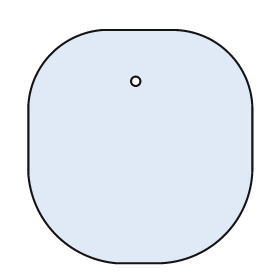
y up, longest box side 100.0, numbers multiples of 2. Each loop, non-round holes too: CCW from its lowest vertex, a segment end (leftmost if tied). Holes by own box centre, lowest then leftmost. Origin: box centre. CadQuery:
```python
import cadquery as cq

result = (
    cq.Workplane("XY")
    .moveTo(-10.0, -50.0)
    .lineTo(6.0, -50.0)
    .threePointArc((36.0, -38.0), (48.0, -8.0))
    .lineTo(48.0, 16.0)
    .threePointArc((38.0, 40.0), (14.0, 50.0))
    .lineTo(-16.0, 50.0)
    .threePointArc((-38.0, 40.0), (-48.0, 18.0))
    .lineTo(-48.0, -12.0)
    .threePointArc((-36.0, -38.0), (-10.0, -50.0))
    .close()
    .moveTo(-2.0, 28.0)
    .circle(2.0)
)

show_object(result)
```